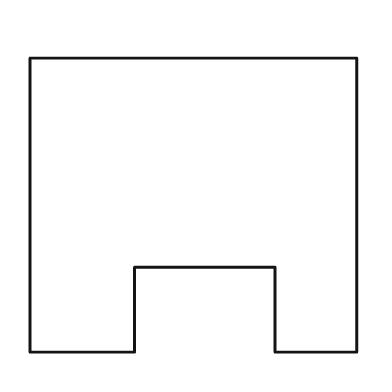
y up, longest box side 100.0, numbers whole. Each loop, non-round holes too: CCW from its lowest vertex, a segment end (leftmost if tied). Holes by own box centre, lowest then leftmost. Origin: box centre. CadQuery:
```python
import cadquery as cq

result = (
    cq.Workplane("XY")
    .moveTo(-50.0, -45.0)
    .lineTo(-18.0, -45.0)
    .lineTo(-18.0, -19.0)
    .lineTo(25.0, -19.0)
    .lineTo(25.0, -45.0)
    .lineTo(50.0, -45.0)
    .lineTo(50.0, 45.0)
    .lineTo(-50.0, 45.0)
    .close()
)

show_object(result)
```